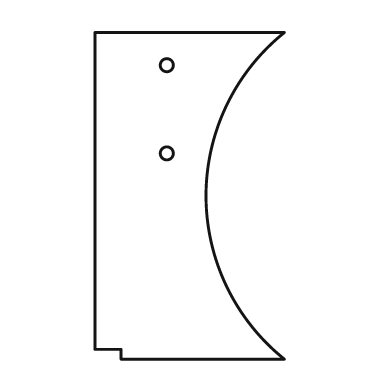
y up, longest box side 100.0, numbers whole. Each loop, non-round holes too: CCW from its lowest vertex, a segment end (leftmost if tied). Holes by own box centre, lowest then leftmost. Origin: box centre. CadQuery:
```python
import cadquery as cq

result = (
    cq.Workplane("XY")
    .moveTo(-21.0, -50.0)
    .lineTo(29.0, -50.0)
    .threePointArc((5.0, 0.0), (29.0, 50.0))
    .lineTo(-29.0, 50.0)
    .lineTo(-29.0, -47.0)
    .lineTo(-21.0, -47.0)
    .close()
    .moveTo(-7.0, 13.0)
    .circle(2.0)
    .moveTo(-7.0, 40.0)
    .circle(2.0)
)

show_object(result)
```